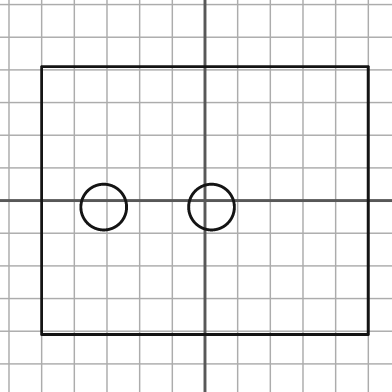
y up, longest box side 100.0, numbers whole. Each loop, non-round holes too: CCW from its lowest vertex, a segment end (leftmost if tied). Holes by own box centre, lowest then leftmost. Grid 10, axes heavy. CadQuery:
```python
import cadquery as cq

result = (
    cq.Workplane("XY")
    .moveTo(-50.0, -41.0)
    .lineTo(50.0, -41.0)
    .lineTo(50.0, 41.0)
    .lineTo(-50.0, 41.0)
    .close()
    .moveTo(-31.0, -2.0)
    .circle(7.0)
    .moveTo(2.0, -2.0)
    .circle(7.0)
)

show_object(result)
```